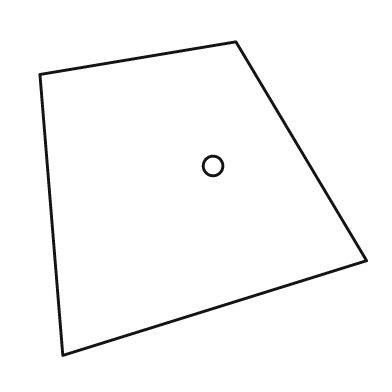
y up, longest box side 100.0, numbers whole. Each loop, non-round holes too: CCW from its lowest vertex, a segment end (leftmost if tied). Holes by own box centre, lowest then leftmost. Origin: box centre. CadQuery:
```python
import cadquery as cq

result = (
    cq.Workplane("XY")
    .moveTo(-43.0, -48.0)
    .lineTo(50.0, -19.0)
    .lineTo(10.0, 48.0)
    .lineTo(-50.0, 38.0)
    .close()
    .moveTo(3.0, 10.0)
    .circle(3.0)
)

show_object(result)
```